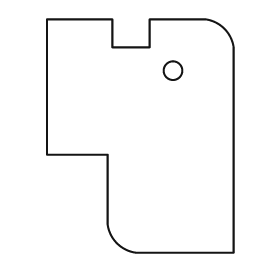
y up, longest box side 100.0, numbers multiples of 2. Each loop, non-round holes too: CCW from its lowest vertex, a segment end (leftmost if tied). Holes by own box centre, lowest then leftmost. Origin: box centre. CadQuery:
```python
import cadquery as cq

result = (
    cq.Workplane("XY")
    .moveTo(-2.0, -50.0)
    .lineTo(40.0, -50.0)
    .lineTo(40.0, 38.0)
    .threePointArc((36.0, 46.0), (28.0, 50.0))
    .lineTo(4.0, 50.0)
    .lineTo(4.0, 38.0)
    .lineTo(-12.0, 38.0)
    .lineTo(-12.0, 50.0)
    .lineTo(-40.0, 50.0)
    .lineTo(-40.0, -8.0)
    .lineTo(-14.0, -8.0)
    .lineTo(-14.0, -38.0)
    .threePointArc((-10.0, -46.0), (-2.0, -50.0))
    .close()
    .moveTo(14.0, 28.0)
    .circle(4.0)
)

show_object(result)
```